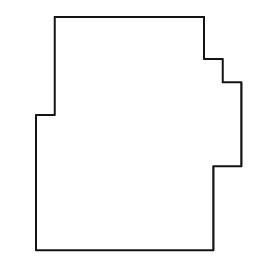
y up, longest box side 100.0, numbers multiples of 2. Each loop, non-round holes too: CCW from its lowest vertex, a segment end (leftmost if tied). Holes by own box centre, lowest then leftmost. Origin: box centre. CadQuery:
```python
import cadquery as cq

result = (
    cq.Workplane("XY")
    .moveTo(-44.0, -50.0)
    .lineTo(32.0, -50.0)
    .lineTo(32.0, -14.0)
    .lineTo(44.0, -14.0)
    .lineTo(44.0, 22.0)
    .lineTo(36.0, 22.0)
    .lineTo(36.0, 32.0)
    .lineTo(28.0, 32.0)
    .lineTo(28.0, 50.0)
    .lineTo(-36.0, 50.0)
    .lineTo(-36.0, 8.0)
    .lineTo(-44.0, 8.0)
    .close()
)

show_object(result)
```